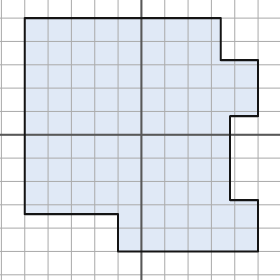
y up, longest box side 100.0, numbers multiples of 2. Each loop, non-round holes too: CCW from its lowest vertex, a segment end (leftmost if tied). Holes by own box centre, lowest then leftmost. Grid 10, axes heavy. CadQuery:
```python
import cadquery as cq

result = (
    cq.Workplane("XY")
    .moveTo(-10.0, -50.0)
    .lineTo(50.0, -50.0)
    .lineTo(50.0, -28.0)
    .lineTo(38.0, -28.0)
    .lineTo(38.0, 8.0)
    .lineTo(50.0, 8.0)
    .lineTo(50.0, 32.0)
    .lineTo(34.0, 32.0)
    .lineTo(34.0, 50.0)
    .lineTo(-50.0, 50.0)
    .lineTo(-50.0, -34.0)
    .lineTo(-10.0, -34.0)
    .close()
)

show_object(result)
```